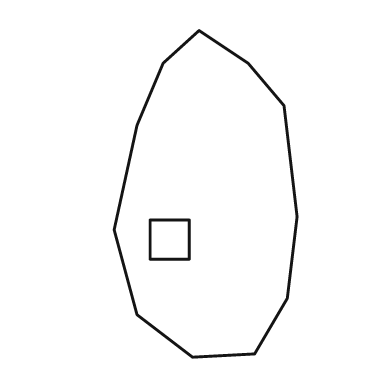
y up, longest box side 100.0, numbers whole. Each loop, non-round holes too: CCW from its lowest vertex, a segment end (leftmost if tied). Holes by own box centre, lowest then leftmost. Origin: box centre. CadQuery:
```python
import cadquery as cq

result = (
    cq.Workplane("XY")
    .moveTo(-4.0, -50.0)
    .lineTo(15.0, -49.0)
    .lineTo(25.0, -32.0)
    .lineTo(28.0, -7.0)
    .lineTo(24.0, 27.0)
    .lineTo(13.0, 40.0)
    .lineTo(-2.0, 50.0)
    .lineTo(-13.0, 40.0)
    .lineTo(-21.0, 21.0)
    .lineTo(-28.0, -11.0)
    .lineTo(-21.0, -37.0)
    .close()
    .moveTo(-17.0, -20.0)
    .lineTo(-5.0, -20.0)
    .lineTo(-5.0, -8.0)
    .lineTo(-17.0, -8.0)
    .close()
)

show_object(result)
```